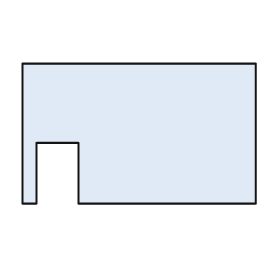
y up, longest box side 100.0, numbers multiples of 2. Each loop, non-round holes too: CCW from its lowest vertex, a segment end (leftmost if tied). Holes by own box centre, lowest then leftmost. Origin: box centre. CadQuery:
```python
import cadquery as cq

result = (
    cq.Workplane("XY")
    .moveTo(-50.0, -30.0)
    .lineTo(-44.0, -30.0)
    .lineTo(-44.0, -4.0)
    .lineTo(-26.0, -4.0)
    .lineTo(-26.0, -30.0)
    .lineTo(50.0, -30.0)
    .lineTo(50.0, 30.0)
    .lineTo(-50.0, 30.0)
    .close()
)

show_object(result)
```